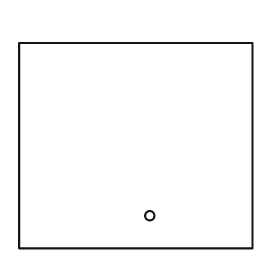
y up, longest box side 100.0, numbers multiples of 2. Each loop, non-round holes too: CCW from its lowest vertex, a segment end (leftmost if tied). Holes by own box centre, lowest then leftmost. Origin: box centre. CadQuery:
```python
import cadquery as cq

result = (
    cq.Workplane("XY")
    .moveTo(-50.0, -44.0)
    .lineTo(50.0, -44.0)
    .lineTo(50.0, 44.0)
    .lineTo(-50.0, 44.0)
    .close()
    .moveTo(6.0, -30.0)
    .circle(2.0)
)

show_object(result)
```